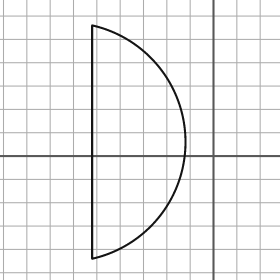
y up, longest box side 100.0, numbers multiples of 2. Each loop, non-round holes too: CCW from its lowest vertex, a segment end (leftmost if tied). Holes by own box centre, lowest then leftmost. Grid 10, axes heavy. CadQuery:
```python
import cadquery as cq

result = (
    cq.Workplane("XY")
    .moveTo(-52.0, -44.0)
    .threePointArc((-12.0, 6.0), (-52.0, 56.0))
    .close()
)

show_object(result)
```